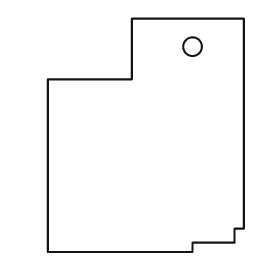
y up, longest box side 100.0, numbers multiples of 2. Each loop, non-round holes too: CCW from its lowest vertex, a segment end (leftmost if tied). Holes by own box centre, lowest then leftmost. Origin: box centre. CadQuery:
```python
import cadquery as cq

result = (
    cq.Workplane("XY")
    .moveTo(-42.0, -50.0)
    .lineTo(20.0, -50.0)
    .lineTo(20.0, -46.0)
    .lineTo(38.0, -46.0)
    .lineTo(38.0, -40.0)
    .lineTo(42.0, -40.0)
    .lineTo(42.0, 50.0)
    .lineTo(-6.0, 50.0)
    .lineTo(-6.0, 24.0)
    .lineTo(-42.0, 24.0)
    .close()
    .moveTo(20.0, 38.0)
    .circle(4.0)
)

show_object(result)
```